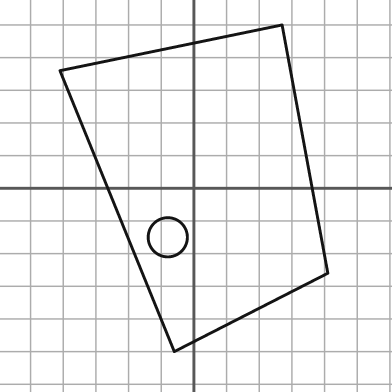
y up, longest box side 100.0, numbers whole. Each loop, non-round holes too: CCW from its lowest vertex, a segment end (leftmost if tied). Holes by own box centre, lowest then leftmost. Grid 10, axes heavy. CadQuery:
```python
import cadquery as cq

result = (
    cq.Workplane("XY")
    .moveTo(-6.0, -50.0)
    .lineTo(41.0, -26.0)
    .lineTo(27.0, 50.0)
    .lineTo(-41.0, 36.0)
    .close()
    .moveTo(-8.0, -15.0)
    .circle(6.0)
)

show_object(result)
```